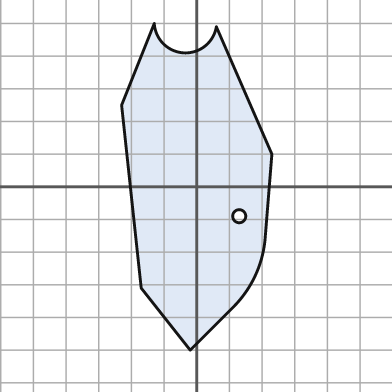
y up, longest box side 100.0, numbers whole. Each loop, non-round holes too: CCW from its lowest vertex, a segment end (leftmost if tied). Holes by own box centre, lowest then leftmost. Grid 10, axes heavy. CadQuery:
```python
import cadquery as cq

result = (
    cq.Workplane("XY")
    .moveTo(-2.0, -50.0)
    .lineTo(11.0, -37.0)
    .threePointArc((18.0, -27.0), (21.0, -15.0))
    .lineTo(23.0, 10.0)
    .lineTo(6.0, 49.0)
    .threePointArc((-4.0, 41.0), (-13.0, 50.0))
    .lineTo(-23.0, 25.0)
    .lineTo(-17.0, -31.0)
    .close()
    .moveTo(13.0, -9.0)
    .circle(2.0)
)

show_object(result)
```